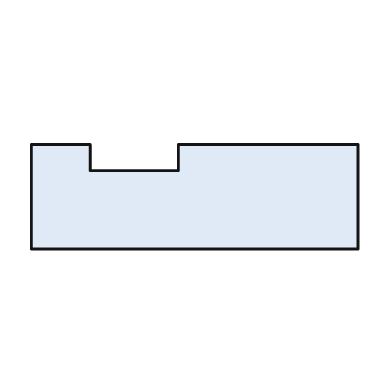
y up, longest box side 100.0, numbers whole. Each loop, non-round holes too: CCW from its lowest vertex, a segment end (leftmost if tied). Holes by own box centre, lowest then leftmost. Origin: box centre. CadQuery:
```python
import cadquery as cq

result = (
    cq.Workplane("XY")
    .moveTo(-50.0, -16.0)
    .lineTo(50.0, -16.0)
    .lineTo(50.0, 16.0)
    .lineTo(-5.0, 16.0)
    .lineTo(-5.0, 8.0)
    .lineTo(-32.0, 8.0)
    .lineTo(-32.0, 16.0)
    .lineTo(-50.0, 16.0)
    .close()
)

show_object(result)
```